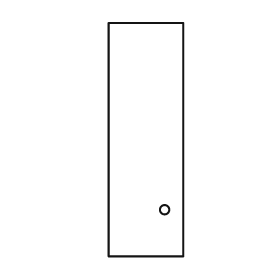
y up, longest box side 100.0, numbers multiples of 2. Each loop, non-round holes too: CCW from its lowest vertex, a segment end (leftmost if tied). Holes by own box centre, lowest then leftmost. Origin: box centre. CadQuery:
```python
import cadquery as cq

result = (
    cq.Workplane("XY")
    .moveTo(-16.0, -50.0)
    .lineTo(16.0, -50.0)
    .lineTo(16.0, 50.0)
    .lineTo(-16.0, 50.0)
    .close()
    .moveTo(8.0, -30.0)
    .circle(2.0)
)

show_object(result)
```